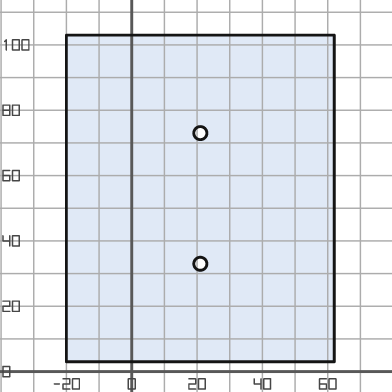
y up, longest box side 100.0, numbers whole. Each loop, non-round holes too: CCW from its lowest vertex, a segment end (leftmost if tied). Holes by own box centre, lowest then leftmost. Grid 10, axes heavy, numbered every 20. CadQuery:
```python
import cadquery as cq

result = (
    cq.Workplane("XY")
    .moveTo(-20.0, 3.0)
    .lineTo(62.0, 3.0)
    .lineTo(62.0, 103.0)
    .lineTo(-20.0, 103.0)
    .close()
    .moveTo(21.0, 33.0)
    .circle(2.0)
    .moveTo(21.0, 73.0)
    .circle(2.0)
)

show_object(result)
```